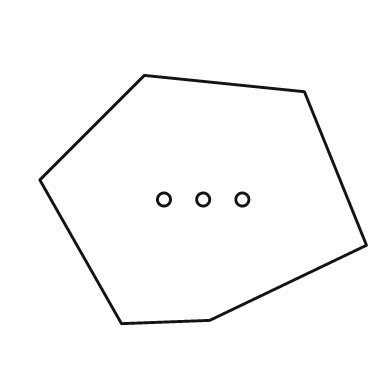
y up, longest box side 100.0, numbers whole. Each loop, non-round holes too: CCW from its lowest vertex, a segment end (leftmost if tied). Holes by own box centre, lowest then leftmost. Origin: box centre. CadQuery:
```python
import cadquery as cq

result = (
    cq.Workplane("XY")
    .moveTo(-25.0, -38.0)
    .lineTo(2.0, -37.0)
    .lineTo(50.0, -14.0)
    .lineTo(31.0, 33.0)
    .lineTo(-18.0, 38.0)
    .lineTo(-50.0, 6.0)
    .close()
    .moveTo(-12.0, 0.0)
    .circle(2.0)
    .moveTo(0.0, 0.0)
    .circle(2.0)
    .moveTo(12.0, 0.0)
    .circle(2.0)
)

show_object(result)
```